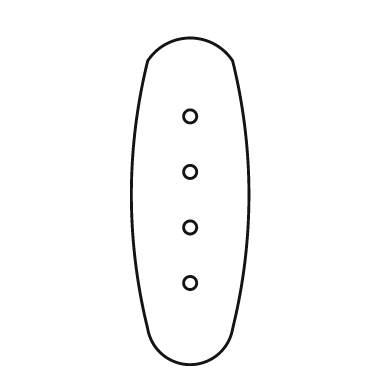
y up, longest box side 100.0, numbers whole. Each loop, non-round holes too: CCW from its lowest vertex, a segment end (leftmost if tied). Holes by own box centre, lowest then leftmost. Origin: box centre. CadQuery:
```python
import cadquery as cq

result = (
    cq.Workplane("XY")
    .moveTo(-13.0, -39.0)
    .threePointArc((0.0, -50.0), (13.0, -39.0))
    .threePointArc((18.0, 2.0), (13.0, 43.0))
    .threePointArc((0.0, 50.0), (-13.0, 43.0))
    .threePointArc((-18.0, 2.0), (-13.0, -39.0))
    .close()
    .moveTo(0.0, -25.0)
    .circle(2.0)
    .moveTo(0.0, -8.0)
    .circle(2.0)
    .moveTo(0.0, 9.0)
    .circle(2.0)
    .moveTo(0.0, 26.0)
    .circle(2.0)
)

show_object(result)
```